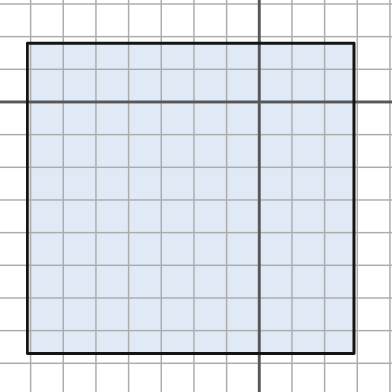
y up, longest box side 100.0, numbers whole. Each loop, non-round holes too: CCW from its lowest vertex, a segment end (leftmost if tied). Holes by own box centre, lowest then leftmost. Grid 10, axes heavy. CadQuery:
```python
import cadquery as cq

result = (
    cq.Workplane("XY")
    .moveTo(-71.0, -77.0)
    .lineTo(29.0, -77.0)
    .lineTo(29.0, 18.0)
    .lineTo(-71.0, 18.0)
    .close()
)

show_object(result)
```